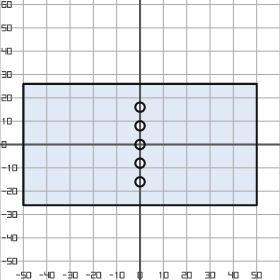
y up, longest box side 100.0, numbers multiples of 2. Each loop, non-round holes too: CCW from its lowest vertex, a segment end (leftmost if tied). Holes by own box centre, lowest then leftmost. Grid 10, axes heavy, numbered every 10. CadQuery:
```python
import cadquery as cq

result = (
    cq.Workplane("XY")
    .moveTo(-50.0, -26.0)
    .lineTo(50.0, -26.0)
    .lineTo(50.0, 26.0)
    .lineTo(-50.0, 26.0)
    .close()
    .moveTo(0.0, -16.0)
    .circle(2.0)
    .moveTo(0.0, -8.0)
    .circle(2.0)
    .moveTo(0.0, 0.0)
    .circle(2.0)
    .moveTo(0.0, 8.0)
    .circle(2.0)
    .moveTo(0.0, 16.0)
    .circle(2.0)
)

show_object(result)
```